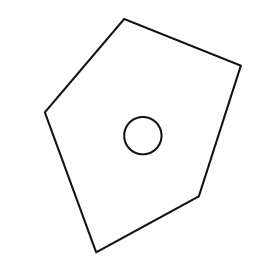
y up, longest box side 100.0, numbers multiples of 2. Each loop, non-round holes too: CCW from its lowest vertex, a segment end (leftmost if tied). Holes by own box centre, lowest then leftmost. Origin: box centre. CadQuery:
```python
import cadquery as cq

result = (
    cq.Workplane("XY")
    .moveTo(-20.0, -50.0)
    .lineTo(24.0, -26.0)
    .lineTo(42.0, 30.0)
    .lineTo(-8.0, 50.0)
    .lineTo(-42.0, 10.0)
    .close()
    .moveTo(0.0, 0.0)
    .circle(8.0)
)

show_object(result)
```